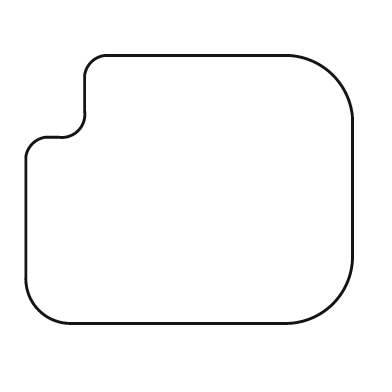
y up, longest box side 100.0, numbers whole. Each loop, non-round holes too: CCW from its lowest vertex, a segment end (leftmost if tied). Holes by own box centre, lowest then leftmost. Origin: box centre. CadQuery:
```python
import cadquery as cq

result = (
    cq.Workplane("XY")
    .moveTo(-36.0, -41.0)
    .lineTo(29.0, -41.0)
    .threePointArc((44.0, -35.0), (50.0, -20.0))
    .lineTo(50.0, 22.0)
    .threePointArc((44.0, 35.0), (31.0, 41.0))
    .lineTo(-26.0, 41.0)
    .threePointArc((-30.0, 39.0), (-32.0, 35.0))
    .lineTo(-32.0, 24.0)
    .threePointArc((-34.0, 18.0), (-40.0, 16.0))
    .lineTo(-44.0, 16.0)
    .threePointArc((-48.0, 14.0), (-50.0, 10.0))
    .lineTo(-50.0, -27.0)
    .threePointArc((-46.0, -37.0), (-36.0, -41.0))
    .close()
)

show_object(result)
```